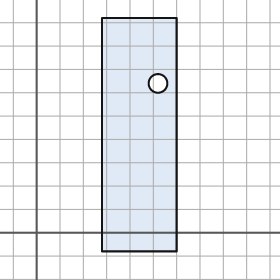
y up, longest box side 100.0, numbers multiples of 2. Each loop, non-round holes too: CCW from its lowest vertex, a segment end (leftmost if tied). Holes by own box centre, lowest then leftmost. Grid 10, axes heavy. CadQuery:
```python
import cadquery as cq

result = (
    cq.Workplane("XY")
    .moveTo(28.0, -8.0)
    .lineTo(60.0, -8.0)
    .lineTo(60.0, 92.0)
    .lineTo(28.0, 92.0)
    .close()
    .moveTo(52.0, 64.0)
    .circle(4.0)
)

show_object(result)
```